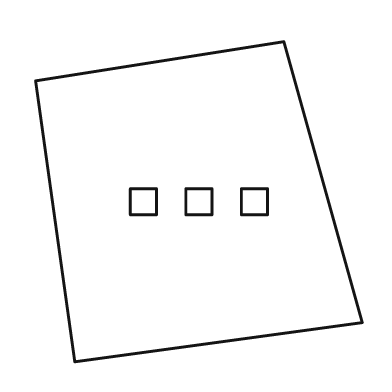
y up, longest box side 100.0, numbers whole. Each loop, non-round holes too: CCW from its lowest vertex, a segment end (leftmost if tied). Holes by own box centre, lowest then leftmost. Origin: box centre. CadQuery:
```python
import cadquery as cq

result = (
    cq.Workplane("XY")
    .moveTo(-38.0, -49.0)
    .lineTo(50.0, -37.0)
    .lineTo(26.0, 49.0)
    .lineTo(-50.0, 37.0)
    .close()
    .moveTo(-21.0, -4.0)
    .lineTo(-13.0, -4.0)
    .lineTo(-13.0, 4.0)
    .lineTo(-21.0, 4.0)
    .close()
    .moveTo(-4.0, -4.0)
    .lineTo(4.0, -4.0)
    .lineTo(4.0, 4.0)
    .lineTo(-4.0, 4.0)
    .close()
    .moveTo(13.0, -4.0)
    .lineTo(21.0, -4.0)
    .lineTo(21.0, 4.0)
    .lineTo(13.0, 4.0)
    .close()
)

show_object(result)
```